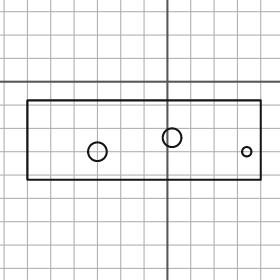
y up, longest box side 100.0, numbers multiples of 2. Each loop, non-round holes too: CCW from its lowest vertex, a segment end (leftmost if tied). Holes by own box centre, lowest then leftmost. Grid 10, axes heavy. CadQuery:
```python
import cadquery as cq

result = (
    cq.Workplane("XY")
    .moveTo(-60.0, -42.0)
    .lineTo(40.0, -42.0)
    .lineTo(40.0, -8.0)
    .lineTo(-60.0, -8.0)
    .close()
    .moveTo(-30.0, -30.0)
    .circle(4.0)
    .moveTo(34.0, -30.0)
    .circle(2.0)
    .moveTo(2.0, -24.0)
    .circle(4.0)
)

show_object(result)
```